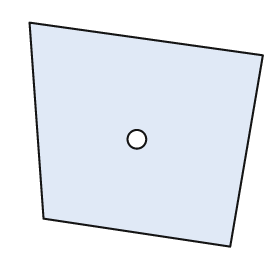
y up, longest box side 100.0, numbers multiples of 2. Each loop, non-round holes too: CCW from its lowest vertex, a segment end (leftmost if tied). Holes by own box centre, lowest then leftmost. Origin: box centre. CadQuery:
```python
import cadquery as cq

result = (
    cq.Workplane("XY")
    .moveTo(36.0, -48.0)
    .lineTo(50.0, 34.0)
    .lineTo(-50.0, 48.0)
    .lineTo(-44.0, -36.0)
    .close()
    .moveTo(-4.0, -2.0)
    .circle(4.0)
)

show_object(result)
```